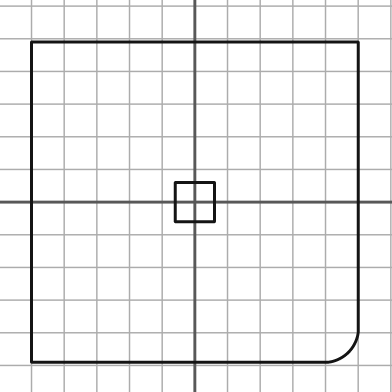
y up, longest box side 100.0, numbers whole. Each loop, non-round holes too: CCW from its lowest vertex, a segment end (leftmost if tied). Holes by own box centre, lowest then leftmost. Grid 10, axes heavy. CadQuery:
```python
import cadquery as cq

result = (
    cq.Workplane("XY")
    .moveTo(-50.0, -49.0)
    .lineTo(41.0, -49.0)
    .threePointArc((47.0, -46.0), (50.0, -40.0))
    .lineTo(50.0, 49.0)
    .lineTo(-50.0, 49.0)
    .close()
    .moveTo(-6.0, -6.0)
    .lineTo(6.0, -6.0)
    .lineTo(6.0, 6.0)
    .lineTo(-6.0, 6.0)
    .close()
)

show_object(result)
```